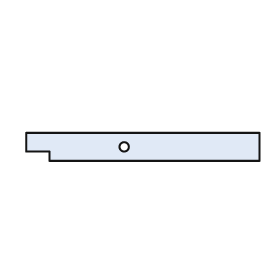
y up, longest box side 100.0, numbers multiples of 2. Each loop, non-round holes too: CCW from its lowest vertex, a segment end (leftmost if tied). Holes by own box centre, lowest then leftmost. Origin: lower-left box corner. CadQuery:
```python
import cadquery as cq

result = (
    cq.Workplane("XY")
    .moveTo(10.0, 0.0)
    .lineTo(100.0, 0.0)
    .lineTo(100.0, 12.0)
    .lineTo(0.0, 12.0)
    .lineTo(0.0, 4.0)
    .lineTo(10.0, 4.0)
    .close()
    .moveTo(42.0, 6.0)
    .circle(2.0)
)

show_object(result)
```